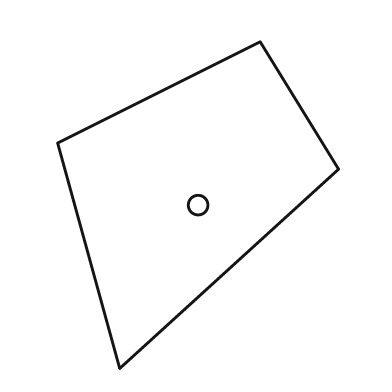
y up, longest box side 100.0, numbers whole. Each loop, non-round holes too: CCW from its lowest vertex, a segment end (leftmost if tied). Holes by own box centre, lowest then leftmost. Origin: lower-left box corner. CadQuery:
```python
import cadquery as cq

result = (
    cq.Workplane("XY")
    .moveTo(19.0, 0.0)
    .lineTo(86.0, 61.0)
    .lineTo(62.0, 100.0)
    .lineTo(0.0, 69.0)
    .close()
    .moveTo(43.0, 50.0)
    .circle(3.0)
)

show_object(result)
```